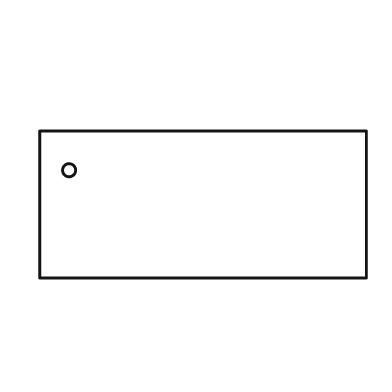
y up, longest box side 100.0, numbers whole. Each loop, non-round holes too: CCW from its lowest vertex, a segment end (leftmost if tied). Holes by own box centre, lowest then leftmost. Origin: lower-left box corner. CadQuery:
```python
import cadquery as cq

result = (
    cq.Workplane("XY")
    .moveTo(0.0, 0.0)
    .lineTo(100.0, 0.0)
    .lineTo(100.0, 45.0)
    .lineTo(0.0, 45.0)
    .close()
    .moveTo(9.0, 33.0)
    .circle(2.0)
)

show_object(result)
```